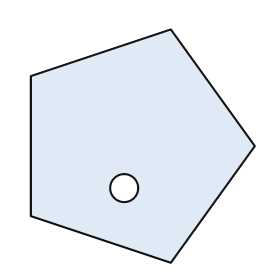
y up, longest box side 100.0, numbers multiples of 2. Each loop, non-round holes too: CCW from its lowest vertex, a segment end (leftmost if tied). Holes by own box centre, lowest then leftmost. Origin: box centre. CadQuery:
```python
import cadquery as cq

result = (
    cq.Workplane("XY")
    .moveTo(12.0, -50.0)
    .lineTo(48.0, 0.0)
    .lineTo(12.0, 50.0)
    .lineTo(-48.0, 30.0)
    .lineTo(-48.0, -30.0)
    .close()
    .moveTo(-8.0, -18.0)
    .circle(6.0)
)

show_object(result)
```